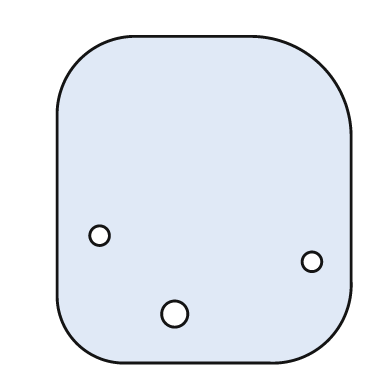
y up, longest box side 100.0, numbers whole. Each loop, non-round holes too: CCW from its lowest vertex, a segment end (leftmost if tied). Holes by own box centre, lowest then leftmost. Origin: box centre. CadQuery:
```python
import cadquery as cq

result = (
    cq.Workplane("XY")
    .moveTo(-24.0, -50.0)
    .lineTo(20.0, -50.0)
    .threePointArc((38.0, -43.0), (45.0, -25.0))
    .lineTo(45.0, 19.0)
    .threePointArc((36.0, 41.0), (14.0, 50.0))
    .lineTo(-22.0, 50.0)
    .threePointArc((-38.0, 43.0), (-45.0, 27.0))
    .lineTo(-45.0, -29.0)
    .threePointArc((-39.0, -44.0), (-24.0, -50.0))
    .close()
    .moveTo(-9.0, -35.0)
    .circle(4.0)
    .moveTo(33.0, -19.0)
    .circle(3.0)
    .moveTo(-32.0, -11.0)
    .circle(3.0)
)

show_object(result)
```